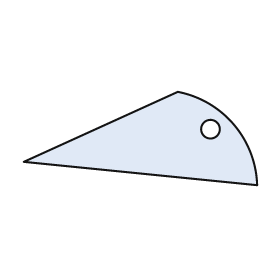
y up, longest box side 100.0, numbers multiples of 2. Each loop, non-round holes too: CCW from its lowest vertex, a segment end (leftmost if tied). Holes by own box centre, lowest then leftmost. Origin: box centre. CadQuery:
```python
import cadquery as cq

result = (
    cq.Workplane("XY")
    .moveTo(50.0, -20.0)
    .threePointArc((40.0, 6.0), (16.0, 20.0))
    .lineTo(-50.0, -10.0)
    .close()
    .moveTo(30.0, 4.0)
    .circle(4.0)
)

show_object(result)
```